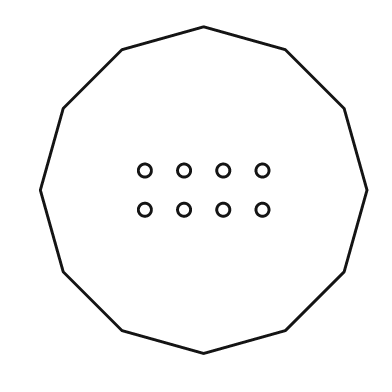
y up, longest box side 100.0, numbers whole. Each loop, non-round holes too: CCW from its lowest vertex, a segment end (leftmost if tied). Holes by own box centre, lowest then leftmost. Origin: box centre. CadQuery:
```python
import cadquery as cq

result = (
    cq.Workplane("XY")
    .moveTo(0.0, -50.0)
    .lineTo(25.0, -43.0)
    .lineTo(43.0, -25.0)
    .lineTo(50.0, 0.0)
    .lineTo(43.0, 25.0)
    .lineTo(25.0, 43.0)
    .lineTo(0.0, 50.0)
    .lineTo(-25.0, 43.0)
    .lineTo(-43.0, 25.0)
    .lineTo(-50.0, 0.0)
    .lineTo(-43.0, -25.0)
    .lineTo(-25.0, -43.0)
    .close()
    .moveTo(-18.0, -6.0)
    .circle(2.0)
    .moveTo(-6.0, -6.0)
    .circle(2.0)
    .moveTo(6.0, -6.0)
    .circle(2.0)
    .moveTo(18.0, -6.0)
    .circle(2.0)
    .moveTo(-18.0, 6.0)
    .circle(2.0)
    .moveTo(-6.0, 6.0)
    .circle(2.0)
    .moveTo(6.0, 6.0)
    .circle(2.0)
    .moveTo(18.0, 6.0)
    .circle(2.0)
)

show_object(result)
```